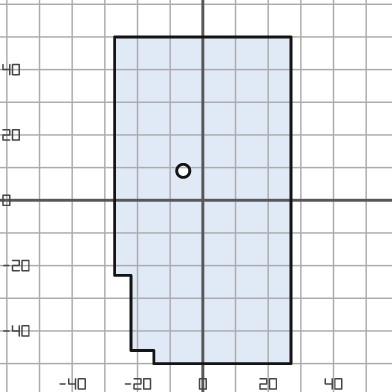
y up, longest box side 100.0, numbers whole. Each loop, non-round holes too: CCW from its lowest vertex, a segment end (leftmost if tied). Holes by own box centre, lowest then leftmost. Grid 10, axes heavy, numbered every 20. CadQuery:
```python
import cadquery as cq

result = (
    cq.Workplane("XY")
    .moveTo(-15.0, -50.0)
    .lineTo(27.0, -50.0)
    .lineTo(27.0, 50.0)
    .lineTo(-27.0, 50.0)
    .lineTo(-27.0, -23.0)
    .lineTo(-22.0, -23.0)
    .lineTo(-22.0, -46.0)
    .lineTo(-15.0, -46.0)
    .close()
    .moveTo(-6.0, 9.0)
    .circle(2.0)
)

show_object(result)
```